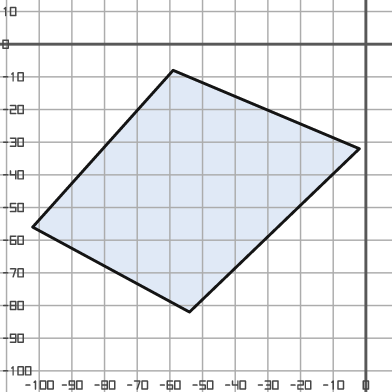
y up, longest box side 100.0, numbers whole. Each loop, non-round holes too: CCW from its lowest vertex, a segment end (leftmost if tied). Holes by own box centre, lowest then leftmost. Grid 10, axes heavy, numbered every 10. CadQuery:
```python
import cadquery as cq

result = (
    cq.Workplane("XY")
    .moveTo(-54.0, -82.0)
    .lineTo(-2.0, -32.0)
    .lineTo(-59.0, -8.0)
    .lineTo(-102.0, -56.0)
    .close()
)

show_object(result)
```